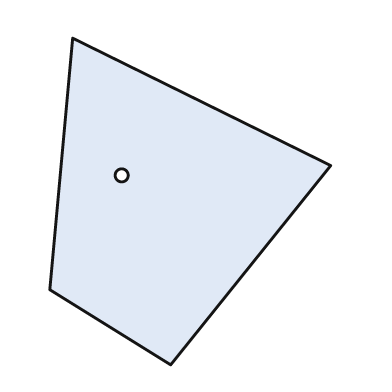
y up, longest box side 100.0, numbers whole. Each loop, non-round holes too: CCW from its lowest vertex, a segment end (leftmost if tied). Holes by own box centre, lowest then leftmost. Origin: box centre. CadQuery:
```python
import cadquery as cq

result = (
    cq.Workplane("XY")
    .moveTo(-6.0, -50.0)
    .lineTo(43.0, 11.0)
    .lineTo(-36.0, 50.0)
    .lineTo(-43.0, -27.0)
    .close()
    .moveTo(-21.0, 8.0)
    .circle(2.0)
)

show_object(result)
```